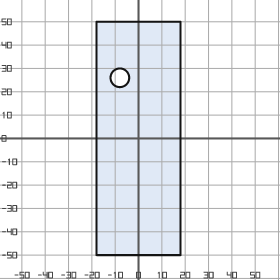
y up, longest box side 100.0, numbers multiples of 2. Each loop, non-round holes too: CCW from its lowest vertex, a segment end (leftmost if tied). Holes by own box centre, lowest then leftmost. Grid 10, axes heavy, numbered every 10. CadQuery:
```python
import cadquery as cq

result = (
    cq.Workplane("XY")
    .moveTo(-18.0, -50.0)
    .lineTo(18.0, -50.0)
    .lineTo(18.0, 50.0)
    .lineTo(-18.0, 50.0)
    .close()
    .moveTo(-8.0, 26.0)
    .circle(4.0)
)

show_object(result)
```